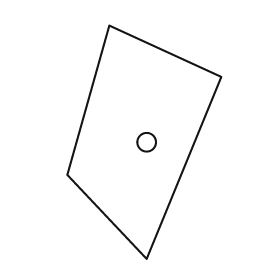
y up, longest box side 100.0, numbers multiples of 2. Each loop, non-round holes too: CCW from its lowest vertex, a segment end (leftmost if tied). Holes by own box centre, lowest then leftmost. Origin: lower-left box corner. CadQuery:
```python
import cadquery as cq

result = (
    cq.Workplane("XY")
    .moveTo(34.0, 0.0)
    .lineTo(66.0, 78.0)
    .lineTo(18.0, 100.0)
    .lineTo(0.0, 36.0)
    .close()
    .moveTo(34.0, 50.0)
    .circle(4.0)
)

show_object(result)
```